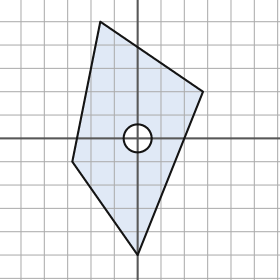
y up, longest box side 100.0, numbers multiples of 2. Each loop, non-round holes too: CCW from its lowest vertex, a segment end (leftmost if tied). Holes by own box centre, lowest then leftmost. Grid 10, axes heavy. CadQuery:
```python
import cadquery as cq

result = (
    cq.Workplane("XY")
    .moveTo(0.0, -50.0)
    .lineTo(28.0, 20.0)
    .lineTo(-16.0, 50.0)
    .lineTo(-28.0, -10.0)
    .close()
    .moveTo(0.0, 0.0)
    .circle(6.0)
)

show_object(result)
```